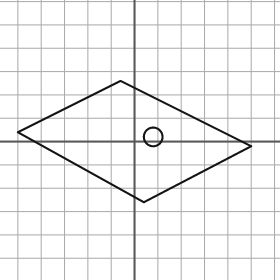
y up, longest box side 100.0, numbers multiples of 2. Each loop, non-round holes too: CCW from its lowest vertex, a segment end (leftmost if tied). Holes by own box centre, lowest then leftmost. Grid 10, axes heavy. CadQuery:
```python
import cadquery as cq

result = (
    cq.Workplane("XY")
    .moveTo(4.0, -26.0)
    .lineTo(50.0, -2.0)
    .lineTo(-6.0, 26.0)
    .lineTo(-50.0, 4.0)
    .close()
    .moveTo(8.0, 2.0)
    .circle(4.0)
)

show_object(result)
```